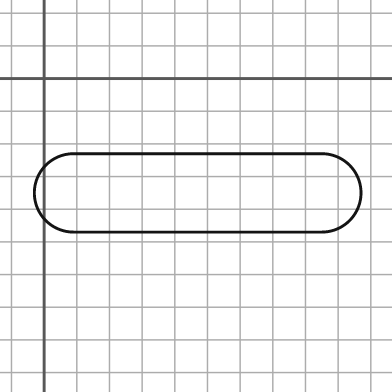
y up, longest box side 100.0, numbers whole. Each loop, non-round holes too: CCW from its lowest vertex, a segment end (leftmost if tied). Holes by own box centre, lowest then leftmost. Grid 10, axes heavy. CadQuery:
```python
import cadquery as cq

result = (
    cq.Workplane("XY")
    .moveTo(9.0, -47.0)
    .lineTo(85.0, -47.0)
    .threePointArc((97.0, -35.0), (85.0, -23.0))
    .lineTo(9.0, -23.0)
    .threePointArc((-3.0, -35.0), (9.0, -47.0))
    .close()
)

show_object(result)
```